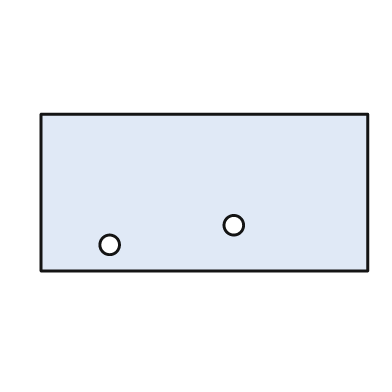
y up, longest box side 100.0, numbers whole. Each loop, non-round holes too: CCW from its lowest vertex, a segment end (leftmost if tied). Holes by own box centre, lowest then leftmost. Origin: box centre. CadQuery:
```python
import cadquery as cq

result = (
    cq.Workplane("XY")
    .moveTo(-50.0, -24.0)
    .lineTo(50.0, -24.0)
    .lineTo(50.0, 24.0)
    .lineTo(-50.0, 24.0)
    .close()
    .moveTo(-29.0, -16.0)
    .circle(3.0)
    .moveTo(9.0, -10.0)
    .circle(3.0)
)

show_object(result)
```